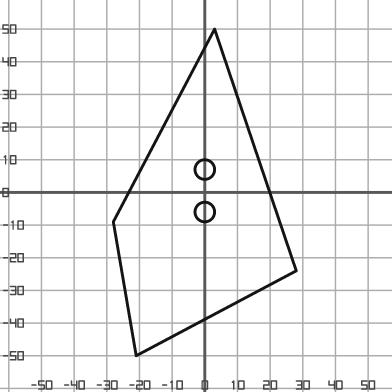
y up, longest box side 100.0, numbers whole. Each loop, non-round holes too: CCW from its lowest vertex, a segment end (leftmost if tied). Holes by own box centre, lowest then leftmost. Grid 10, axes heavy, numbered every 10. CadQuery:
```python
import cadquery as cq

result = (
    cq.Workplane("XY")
    .moveTo(-21.0, -50.0)
    .lineTo(28.0, -24.0)
    .lineTo(3.0, 50.0)
    .lineTo(-28.0, -9.0)
    .close()
    .moveTo(0.0, -6.0)
    .circle(3.0)
    .moveTo(0.0, 7.0)
    .circle(3.0)
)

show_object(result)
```